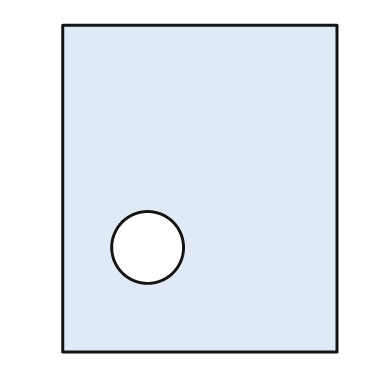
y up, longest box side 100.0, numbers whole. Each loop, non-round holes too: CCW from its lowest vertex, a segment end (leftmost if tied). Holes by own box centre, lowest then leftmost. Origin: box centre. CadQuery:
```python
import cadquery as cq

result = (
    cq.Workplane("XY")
    .moveTo(-42.0, -50.0)
    .lineTo(42.0, -50.0)
    .lineTo(42.0, 50.0)
    .lineTo(-42.0, 50.0)
    .close()
    .moveTo(-16.0, -18.0)
    .circle(11.0)
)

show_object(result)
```